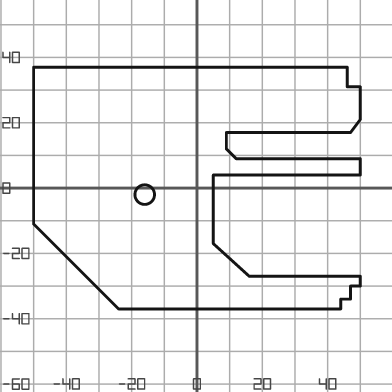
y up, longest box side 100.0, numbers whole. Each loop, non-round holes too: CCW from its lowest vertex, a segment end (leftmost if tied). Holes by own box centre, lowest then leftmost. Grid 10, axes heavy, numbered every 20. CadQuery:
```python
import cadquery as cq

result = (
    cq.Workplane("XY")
    .moveTo(-24.0, -37.0)
    .lineTo(44.0, -37.0)
    .lineTo(44.0, -34.0)
    .lineTo(47.0, -34.0)
    .lineTo(47.0, -30.0)
    .lineTo(50.0, -30.0)
    .lineTo(50.0, -27.0)
    .lineTo(16.0, -27.0)
    .lineTo(5.0, -17.0)
    .lineTo(5.0, 4.0)
    .lineTo(50.0, 4.0)
    .lineTo(50.0, 9.0)
    .lineTo(12.0, 9.0)
    .lineTo(9.0, 12.0)
    .lineTo(9.0, 17.0)
    .lineTo(47.0, 17.0)
    .lineTo(50.0, 21.0)
    .lineTo(50.0, 31.0)
    .lineTo(46.0, 31.0)
    .lineTo(46.0, 37.0)
    .lineTo(-50.0, 37.0)
    .lineTo(-50.0, -11.0)
    .close()
    .moveTo(-16.0, -2.0)
    .circle(3.0)
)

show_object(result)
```